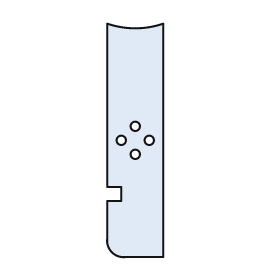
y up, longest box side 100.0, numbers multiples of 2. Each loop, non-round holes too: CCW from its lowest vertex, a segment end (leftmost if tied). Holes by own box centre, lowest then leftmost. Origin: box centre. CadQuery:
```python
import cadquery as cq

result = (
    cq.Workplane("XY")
    .moveTo(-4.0, -50.0)
    .lineTo(12.0, -50.0)
    .lineTo(12.0, 50.0)
    .threePointArc((0.0, 48.0), (-12.0, 50.0))
    .lineTo(-12.0, -20.0)
    .lineTo(-6.0, -20.0)
    .lineTo(-6.0, -26.0)
    .lineTo(-12.0, -26.0)
    .lineTo(-12.0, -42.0)
    .threePointArc((-10.0, -48.0), (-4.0, -50.0))
    .close()
    .moveTo(0.0, -6.0)
    .circle(2.0)
    .moveTo(-6.0, 0.0)
    .circle(2.0)
    .moveTo(6.0, 0.0)
    .circle(2.0)
    .moveTo(0.0, 6.0)
    .circle(2.0)
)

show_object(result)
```